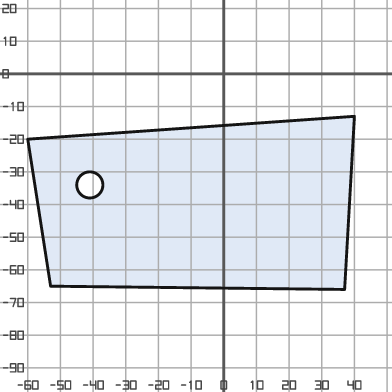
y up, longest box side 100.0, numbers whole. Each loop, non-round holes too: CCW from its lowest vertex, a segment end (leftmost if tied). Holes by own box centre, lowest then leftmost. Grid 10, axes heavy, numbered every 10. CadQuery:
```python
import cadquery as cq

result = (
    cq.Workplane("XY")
    .moveTo(37.0, -66.0)
    .lineTo(40.0, -13.0)
    .lineTo(-60.0, -20.0)
    .lineTo(-53.0, -65.0)
    .close()
    .moveTo(-41.0, -34.0)
    .circle(4.0)
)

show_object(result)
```